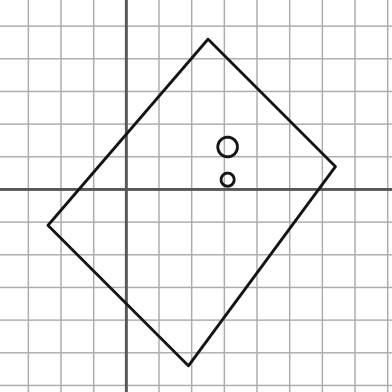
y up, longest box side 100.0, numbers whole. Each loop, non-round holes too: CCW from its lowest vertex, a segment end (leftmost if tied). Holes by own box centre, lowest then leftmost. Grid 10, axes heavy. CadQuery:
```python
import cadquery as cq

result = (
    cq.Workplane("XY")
    .moveTo(19.0, -54.0)
    .lineTo(64.0, 7.0)
    .lineTo(25.0, 46.0)
    .lineTo(-24.0, -11.0)
    .close()
    .moveTo(31.0, 3.0)
    .circle(2.0)
    .moveTo(31.0, 13.0)
    .circle(3.0)
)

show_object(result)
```